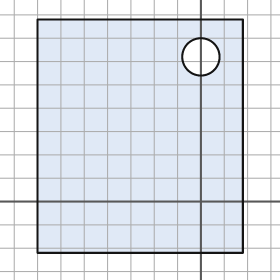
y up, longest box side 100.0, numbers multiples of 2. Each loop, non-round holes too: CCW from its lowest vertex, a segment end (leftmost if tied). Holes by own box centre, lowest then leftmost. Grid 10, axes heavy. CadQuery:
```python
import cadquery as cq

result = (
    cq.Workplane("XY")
    .moveTo(-70.0, -22.0)
    .lineTo(18.0, -22.0)
    .lineTo(18.0, 78.0)
    .lineTo(-70.0, 78.0)
    .close()
    .moveTo(0.0, 62.0)
    .circle(8.0)
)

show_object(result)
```